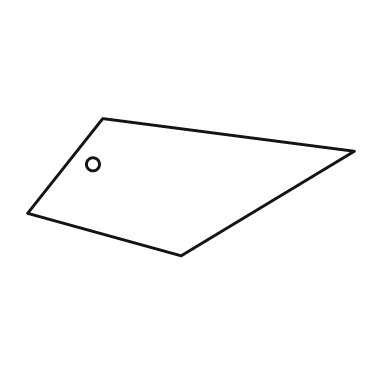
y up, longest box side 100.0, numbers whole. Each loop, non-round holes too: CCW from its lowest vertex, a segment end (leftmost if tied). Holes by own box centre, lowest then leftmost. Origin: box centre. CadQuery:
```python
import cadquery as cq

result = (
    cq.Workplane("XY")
    .moveTo(-3.0, -21.0)
    .lineTo(50.0, 11.0)
    .lineTo(-27.0, 21.0)
    .lineTo(-50.0, -8.0)
    .close()
    .moveTo(-30.0, 7.0)
    .circle(2.0)
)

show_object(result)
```